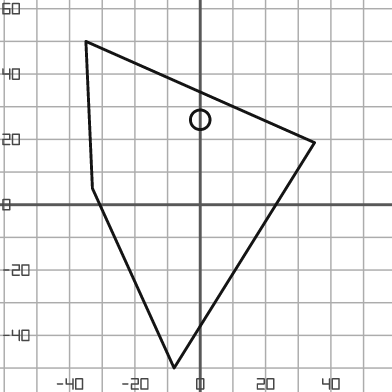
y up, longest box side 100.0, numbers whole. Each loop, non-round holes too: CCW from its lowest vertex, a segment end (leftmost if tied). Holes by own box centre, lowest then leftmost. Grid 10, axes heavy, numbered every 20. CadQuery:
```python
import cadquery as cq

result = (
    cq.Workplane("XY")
    .moveTo(-8.0, -50.0)
    .lineTo(35.0, 19.0)
    .lineTo(-35.0, 50.0)
    .lineTo(-33.0, 5.0)
    .close()
    .moveTo(0.0, 26.0)
    .circle(3.0)
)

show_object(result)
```